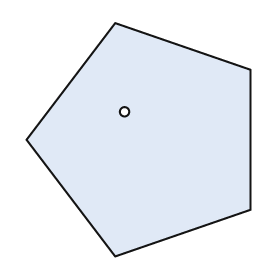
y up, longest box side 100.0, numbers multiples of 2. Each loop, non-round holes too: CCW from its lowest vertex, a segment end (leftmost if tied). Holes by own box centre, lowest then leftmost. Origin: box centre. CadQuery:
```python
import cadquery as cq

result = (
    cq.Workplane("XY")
    .moveTo(-10.0, -50.0)
    .lineTo(48.0, -30.0)
    .lineTo(48.0, 30.0)
    .lineTo(-10.0, 50.0)
    .lineTo(-48.0, 0.0)
    .close()
    .moveTo(-6.0, 12.0)
    .circle(2.0)
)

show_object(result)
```